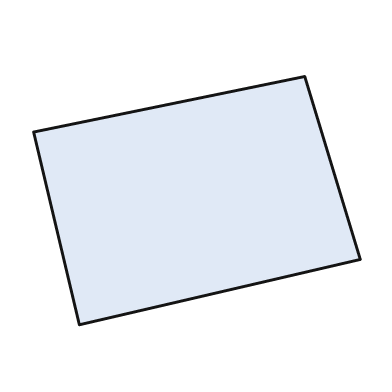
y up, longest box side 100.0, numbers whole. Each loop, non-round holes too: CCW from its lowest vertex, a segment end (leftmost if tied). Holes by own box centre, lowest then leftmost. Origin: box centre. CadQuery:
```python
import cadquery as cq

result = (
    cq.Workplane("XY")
    .moveTo(-36.0, -38.0)
    .lineTo(50.0, -18.0)
    .lineTo(33.0, 38.0)
    .lineTo(-50.0, 21.0)
    .close()
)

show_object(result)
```